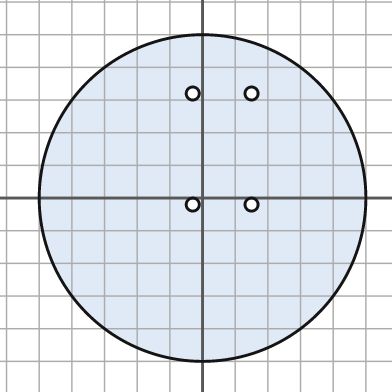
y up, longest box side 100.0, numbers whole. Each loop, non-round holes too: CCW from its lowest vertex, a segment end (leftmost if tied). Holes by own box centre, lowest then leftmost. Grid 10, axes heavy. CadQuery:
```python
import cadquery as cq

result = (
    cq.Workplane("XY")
    .moveTo(0.0, 0.0)
    .circle(50.0)
    .moveTo(-3.0, -2.0)
    .circle(2.0)
    .moveTo(15.0, -2.0)
    .circle(2.0)
    .moveTo(-3.0, 32.0)
    .circle(2.0)
    .moveTo(15.0, 32.0)
    .circle(2.0)
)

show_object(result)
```